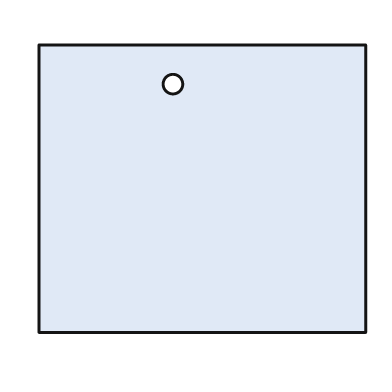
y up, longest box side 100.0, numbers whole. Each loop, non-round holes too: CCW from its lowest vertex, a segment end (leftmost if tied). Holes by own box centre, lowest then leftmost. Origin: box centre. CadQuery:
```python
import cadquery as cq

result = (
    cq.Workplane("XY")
    .moveTo(-50.0, -44.0)
    .lineTo(50.0, -44.0)
    .lineTo(50.0, 44.0)
    .lineTo(-50.0, 44.0)
    .close()
    .moveTo(-9.0, 32.0)
    .circle(3.0)
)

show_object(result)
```